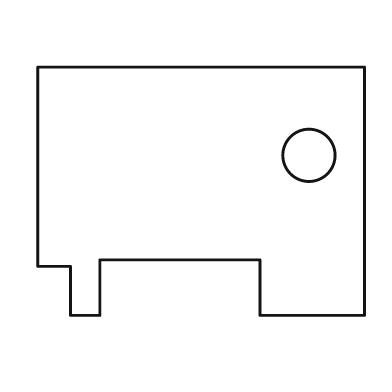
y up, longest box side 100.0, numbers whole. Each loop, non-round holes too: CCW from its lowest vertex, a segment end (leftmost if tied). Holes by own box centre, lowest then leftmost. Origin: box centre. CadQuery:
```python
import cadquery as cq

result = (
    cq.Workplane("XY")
    .moveTo(-40.0, -38.0)
    .lineTo(-31.0, -38.0)
    .lineTo(-31.0, -21.0)
    .lineTo(18.0, -21.0)
    .lineTo(18.0, -38.0)
    .lineTo(50.0, -38.0)
    .lineTo(50.0, 38.0)
    .lineTo(-50.0, 38.0)
    .lineTo(-50.0, -23.0)
    .lineTo(-40.0, -23.0)
    .close()
    .moveTo(33.0, 11.0)
    .circle(8.0)
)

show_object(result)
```